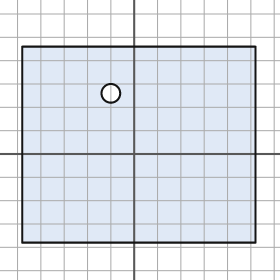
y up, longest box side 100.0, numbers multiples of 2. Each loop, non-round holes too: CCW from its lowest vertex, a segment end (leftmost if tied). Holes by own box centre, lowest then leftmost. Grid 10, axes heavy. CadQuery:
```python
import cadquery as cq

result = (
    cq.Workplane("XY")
    .moveTo(-48.0, -38.0)
    .lineTo(52.0, -38.0)
    .lineTo(52.0, 46.0)
    .lineTo(-48.0, 46.0)
    .close()
    .moveTo(-10.0, 26.0)
    .circle(4.0)
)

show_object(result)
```